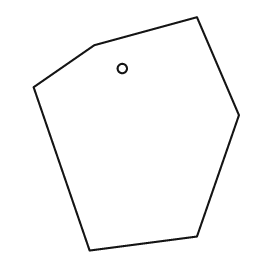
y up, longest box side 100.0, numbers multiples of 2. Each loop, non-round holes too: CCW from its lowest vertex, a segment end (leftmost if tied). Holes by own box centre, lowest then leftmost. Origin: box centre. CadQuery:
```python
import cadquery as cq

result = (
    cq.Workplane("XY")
    .moveTo(-20.0, -50.0)
    .lineTo(26.0, -44.0)
    .lineTo(44.0, 8.0)
    .lineTo(26.0, 50.0)
    .lineTo(-18.0, 38.0)
    .lineTo(-44.0, 20.0)
    .close()
    .moveTo(-6.0, 28.0)
    .circle(2.0)
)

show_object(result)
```